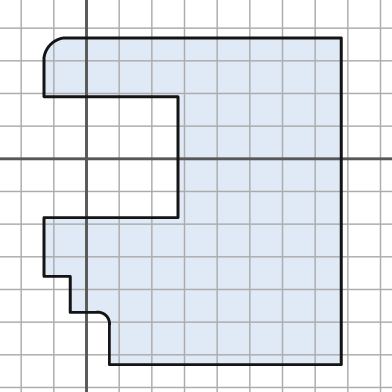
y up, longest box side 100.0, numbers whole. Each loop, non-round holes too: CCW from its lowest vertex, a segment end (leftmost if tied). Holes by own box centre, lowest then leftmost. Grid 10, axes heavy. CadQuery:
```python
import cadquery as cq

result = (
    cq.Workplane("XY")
    .moveTo(7.0, -63.0)
    .lineTo(78.0, -63.0)
    .lineTo(78.0, 37.0)
    .lineTo(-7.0, 37.0)
    .threePointArc((-11.0, 35.0), (-13.0, 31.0))
    .lineTo(-13.0, 19.0)
    .lineTo(28.0, 19.0)
    .lineTo(28.0, -18.0)
    .lineTo(-13.0, -18.0)
    .lineTo(-13.0, -36.0)
    .lineTo(-5.0, -36.0)
    .lineTo(-5.0, -47.0)
    .lineTo(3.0, -47.0)
    .threePointArc((6.0, -48.0), (7.0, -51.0))
    .close()
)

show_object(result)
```